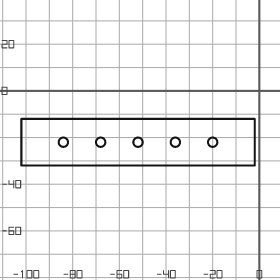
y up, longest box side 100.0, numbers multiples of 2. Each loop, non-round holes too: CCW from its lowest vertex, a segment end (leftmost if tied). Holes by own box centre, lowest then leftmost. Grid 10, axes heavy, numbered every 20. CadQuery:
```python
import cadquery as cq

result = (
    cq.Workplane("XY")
    .moveTo(-102.0, -32.0)
    .lineTo(-2.0, -32.0)
    .lineTo(-2.0, -12.0)
    .lineTo(-102.0, -12.0)
    .close()
    .moveTo(-84.0, -22.0)
    .circle(2.0)
    .moveTo(-68.0, -22.0)
    .circle(2.0)
    .moveTo(-52.0, -22.0)
    .circle(2.0)
    .moveTo(-36.0, -22.0)
    .circle(2.0)
    .moveTo(-20.0, -22.0)
    .circle(2.0)
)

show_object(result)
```